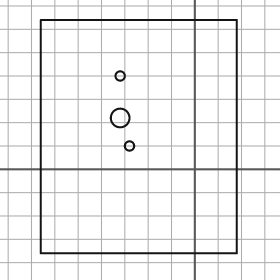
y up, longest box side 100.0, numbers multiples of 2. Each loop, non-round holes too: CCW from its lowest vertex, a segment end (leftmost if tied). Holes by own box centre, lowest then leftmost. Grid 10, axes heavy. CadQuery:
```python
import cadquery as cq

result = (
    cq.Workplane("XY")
    .moveTo(-66.0, -36.0)
    .lineTo(18.0, -36.0)
    .lineTo(18.0, 64.0)
    .lineTo(-66.0, 64.0)
    .close()
    .moveTo(-28.0, 10.0)
    .circle(2.0)
    .moveTo(-32.0, 22.0)
    .circle(4.0)
    .moveTo(-32.0, 40.0)
    .circle(2.0)
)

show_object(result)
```